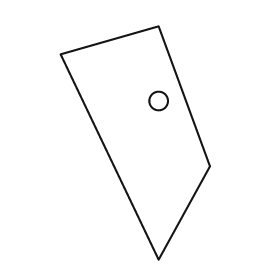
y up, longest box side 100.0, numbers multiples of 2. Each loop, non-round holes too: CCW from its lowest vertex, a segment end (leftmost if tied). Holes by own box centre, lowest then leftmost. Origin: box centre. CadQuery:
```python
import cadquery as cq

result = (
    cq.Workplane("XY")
    .moveTo(10.0, -50.0)
    .lineTo(32.0, -10.0)
    .lineTo(10.0, 50.0)
    .lineTo(-32.0, 38.0)
    .close()
    .moveTo(10.0, 18.0)
    .circle(4.0)
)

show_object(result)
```